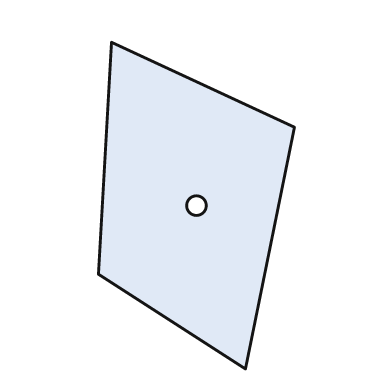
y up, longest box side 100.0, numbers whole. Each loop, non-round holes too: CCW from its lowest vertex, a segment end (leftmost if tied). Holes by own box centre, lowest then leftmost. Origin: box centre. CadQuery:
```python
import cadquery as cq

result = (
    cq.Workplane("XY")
    .moveTo(15.0, -50.0)
    .lineTo(30.0, 24.0)
    .lineTo(-26.0, 50.0)
    .lineTo(-30.0, -21.0)
    .close()
    .moveTo(0.0, 0.0)
    .circle(3.0)
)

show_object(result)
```